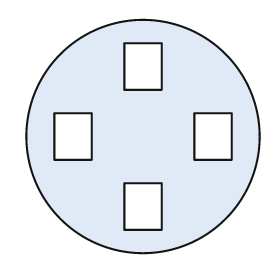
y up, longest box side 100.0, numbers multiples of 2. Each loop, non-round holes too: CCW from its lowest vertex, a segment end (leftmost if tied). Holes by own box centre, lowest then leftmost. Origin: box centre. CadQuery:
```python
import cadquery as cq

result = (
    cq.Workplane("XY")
    .moveTo(0.0, 0.0)
    .circle(50.0)
    .moveTo(-8.0, -40.0)
    .lineTo(8.0, -40.0)
    .lineTo(8.0, -20.0)
    .lineTo(-8.0, -20.0)
    .close()
    .moveTo(-38.0, -10.0)
    .lineTo(-22.0, -10.0)
    .lineTo(-22.0, 10.0)
    .lineTo(-38.0, 10.0)
    .close()
    .moveTo(22.0, -10.0)
    .lineTo(38.0, -10.0)
    .lineTo(38.0, 10.0)
    .lineTo(22.0, 10.0)
    .close()
    .moveTo(-8.0, 20.0)
    .lineTo(8.0, 20.0)
    .lineTo(8.0, 40.0)
    .lineTo(-8.0, 40.0)
    .close()
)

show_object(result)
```